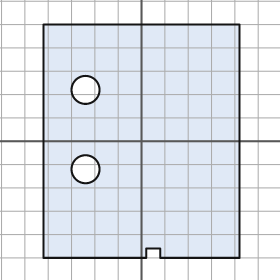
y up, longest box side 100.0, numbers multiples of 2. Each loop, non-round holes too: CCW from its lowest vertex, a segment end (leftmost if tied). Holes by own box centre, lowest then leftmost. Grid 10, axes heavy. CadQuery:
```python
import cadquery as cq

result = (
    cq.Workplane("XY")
    .moveTo(-42.0, -50.0)
    .lineTo(2.0, -50.0)
    .lineTo(2.0, -46.0)
    .lineTo(8.0, -46.0)
    .lineTo(8.0, -50.0)
    .lineTo(42.0, -50.0)
    .lineTo(42.0, 50.0)
    .lineTo(-42.0, 50.0)
    .close()
    .moveTo(-24.0, -12.0)
    .circle(6.0)
    .moveTo(-24.0, 22.0)
    .circle(6.0)
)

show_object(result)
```